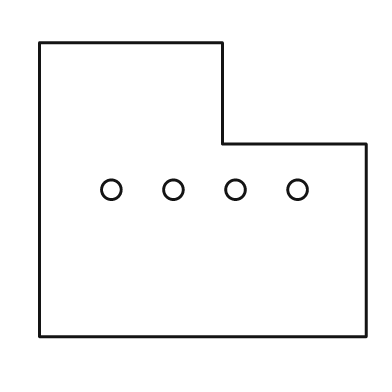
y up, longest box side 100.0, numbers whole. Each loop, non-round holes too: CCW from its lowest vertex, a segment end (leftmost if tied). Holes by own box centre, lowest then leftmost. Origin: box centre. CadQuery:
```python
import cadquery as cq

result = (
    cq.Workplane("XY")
    .moveTo(-50.0, -45.0)
    .lineTo(50.0, -45.0)
    .lineTo(50.0, 14.0)
    .lineTo(6.0, 14.0)
    .lineTo(6.0, 45.0)
    .lineTo(-50.0, 45.0)
    .close()
    .moveTo(-28.0, 0.0)
    .circle(3.0)
    .moveTo(-9.0, 0.0)
    .circle(3.0)
    .moveTo(10.0, 0.0)
    .circle(3.0)
    .moveTo(29.0, 0.0)
    .circle(3.0)
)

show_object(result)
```